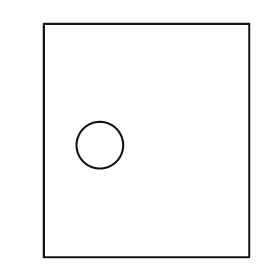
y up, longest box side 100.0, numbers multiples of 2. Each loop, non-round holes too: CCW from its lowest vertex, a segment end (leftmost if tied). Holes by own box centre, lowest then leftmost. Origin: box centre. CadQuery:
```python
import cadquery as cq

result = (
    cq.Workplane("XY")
    .moveTo(-44.0, -50.0)
    .lineTo(44.0, -50.0)
    .lineTo(44.0, 50.0)
    .lineTo(-44.0, 50.0)
    .close()
    .moveTo(-20.0, -2.0)
    .circle(10.0)
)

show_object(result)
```